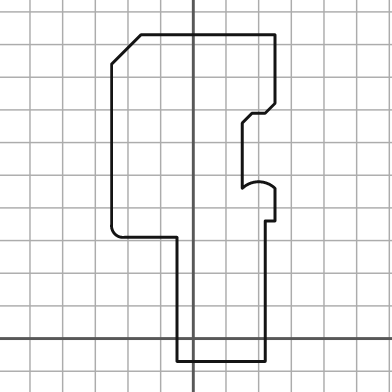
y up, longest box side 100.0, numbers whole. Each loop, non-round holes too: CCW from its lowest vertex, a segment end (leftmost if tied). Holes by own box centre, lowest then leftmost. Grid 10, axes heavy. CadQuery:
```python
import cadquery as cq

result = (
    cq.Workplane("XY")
    .moveTo(-5.0, -7.0)
    .lineTo(22.0, -7.0)
    .lineTo(22.0, 36.0)
    .lineTo(25.0, 36.0)
    .lineTo(25.0, 46.0)
    .threePointArc((20.0, 48.0), (15.0, 46.0))
    .lineTo(15.0, 66.0)
    .lineTo(18.0, 69.0)
    .lineTo(22.0, 69.0)
    .lineTo(25.0, 72.0)
    .lineTo(25.0, 93.0)
    .lineTo(-16.0, 93.0)
    .lineTo(-25.0, 84.0)
    .lineTo(-25.0, 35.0)
    .threePointArc((-24.0, 32.0), (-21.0, 31.0))
    .lineTo(-5.0, 31.0)
    .close()
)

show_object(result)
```